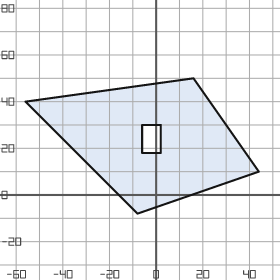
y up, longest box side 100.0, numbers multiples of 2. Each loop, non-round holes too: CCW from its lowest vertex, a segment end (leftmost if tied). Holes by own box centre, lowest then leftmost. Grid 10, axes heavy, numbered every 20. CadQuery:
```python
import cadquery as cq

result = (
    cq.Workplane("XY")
    .moveTo(-8.0, -8.0)
    .lineTo(44.0, 10.0)
    .lineTo(16.0, 50.0)
    .lineTo(-56.0, 40.0)
    .close()
    .moveTo(-6.0, 18.0)
    .lineTo(2.0, 18.0)
    .lineTo(2.0, 30.0)
    .lineTo(-6.0, 30.0)
    .close()
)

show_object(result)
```